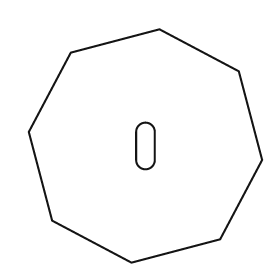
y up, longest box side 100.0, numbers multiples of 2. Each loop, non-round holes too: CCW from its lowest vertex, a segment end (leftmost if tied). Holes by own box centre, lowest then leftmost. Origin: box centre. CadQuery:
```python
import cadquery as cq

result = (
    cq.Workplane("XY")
    .moveTo(-6.0, -50.0)
    .lineTo(32.0, -40.0)
    .lineTo(50.0, -6.0)
    .lineTo(40.0, 32.0)
    .lineTo(6.0, 50.0)
    .lineTo(-32.0, 40.0)
    .lineTo(-50.0, 6.0)
    .lineTo(-40.0, -32.0)
    .close()
    .moveTo(-4.0, -6.0)
    .threePointArc((0.0, -10.0), (4.0, -6.0))
    .lineTo(4.0, 6.0)
    .threePointArc((0.0, 10.0), (-4.0, 6.0))
    .close()
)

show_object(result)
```